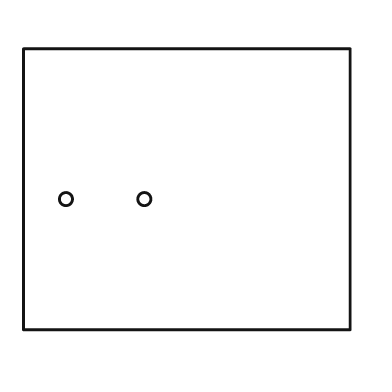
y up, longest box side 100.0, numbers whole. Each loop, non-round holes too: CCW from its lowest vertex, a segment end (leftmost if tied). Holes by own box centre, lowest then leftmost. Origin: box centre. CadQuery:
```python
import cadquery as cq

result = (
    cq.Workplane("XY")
    .moveTo(-50.0, -43.0)
    .lineTo(50.0, -43.0)
    .lineTo(50.0, 43.0)
    .lineTo(-50.0, 43.0)
    .close()
    .moveTo(-37.0, -3.0)
    .circle(2.0)
    .moveTo(-13.0, -3.0)
    .circle(2.0)
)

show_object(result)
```